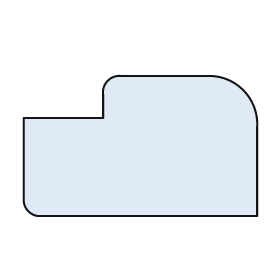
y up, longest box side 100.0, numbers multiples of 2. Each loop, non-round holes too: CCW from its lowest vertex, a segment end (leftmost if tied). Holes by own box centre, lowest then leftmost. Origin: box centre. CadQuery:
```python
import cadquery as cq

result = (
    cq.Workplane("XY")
    .moveTo(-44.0, -30.0)
    .lineTo(50.0, -30.0)
    .lineTo(50.0, 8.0)
    .threePointArc((44.0, 24.0), (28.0, 30.0))
    .lineTo(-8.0, 30.0)
    .threePointArc((-14.0, 28.0), (-16.0, 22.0))
    .lineTo(-16.0, 12.0)
    .lineTo(-50.0, 12.0)
    .lineTo(-50.0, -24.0)
    .threePointArc((-48.0, -28.0), (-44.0, -30.0))
    .close()
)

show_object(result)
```